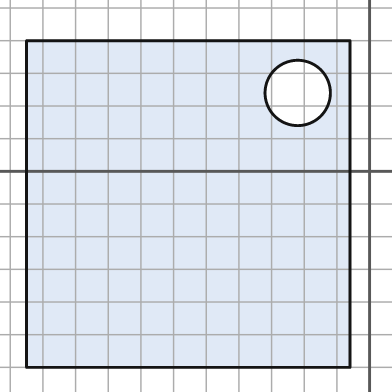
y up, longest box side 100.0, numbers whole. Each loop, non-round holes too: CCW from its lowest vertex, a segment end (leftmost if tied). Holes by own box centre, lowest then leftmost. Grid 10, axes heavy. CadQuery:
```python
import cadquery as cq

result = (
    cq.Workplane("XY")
    .moveTo(-105.0, -60.0)
    .lineTo(-6.0, -60.0)
    .lineTo(-6.0, 40.0)
    .lineTo(-105.0, 40.0)
    .close()
    .moveTo(-22.0, 24.0)
    .circle(10.0)
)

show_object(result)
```